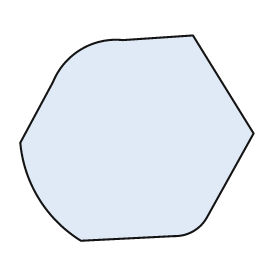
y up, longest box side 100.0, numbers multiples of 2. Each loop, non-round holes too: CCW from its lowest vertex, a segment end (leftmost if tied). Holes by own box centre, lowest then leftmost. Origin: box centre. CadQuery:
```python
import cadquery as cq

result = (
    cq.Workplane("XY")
    .moveTo(-24.0, -44.0)
    .lineTo(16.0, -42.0)
    .threePointArc((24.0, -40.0), (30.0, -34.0))
    .lineTo(50.0, 2.0)
    .lineTo(24.0, 44.0)
    .lineTo(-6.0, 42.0)
    .threePointArc((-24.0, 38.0), (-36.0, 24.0))
    .lineTo(-50.0, -2.0)
    .threePointArc((-42.0, -26.0), (-24.0, -44.0))
    .close()
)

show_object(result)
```